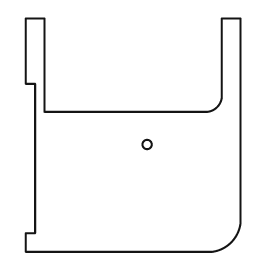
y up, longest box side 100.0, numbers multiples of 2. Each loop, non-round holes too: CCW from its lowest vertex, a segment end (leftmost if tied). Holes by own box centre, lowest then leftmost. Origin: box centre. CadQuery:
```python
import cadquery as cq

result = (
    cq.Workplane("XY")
    .moveTo(-46.0, -50.0)
    .lineTo(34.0, -50.0)
    .threePointArc((42.0, -46.0), (46.0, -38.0))
    .lineTo(46.0, 50.0)
    .lineTo(38.0, 50.0)
    .lineTo(38.0, 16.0)
    .threePointArc((36.0, 12.0), (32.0, 10.0))
    .lineTo(-38.0, 10.0)
    .lineTo(-38.0, 50.0)
    .lineTo(-46.0, 50.0)
    .lineTo(-46.0, 22.0)
    .lineTo(-42.0, 22.0)
    .lineTo(-42.0, -42.0)
    .lineTo(-46.0, -42.0)
    .close()
    .moveTo(6.0, -4.0)
    .circle(2.0)
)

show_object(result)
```